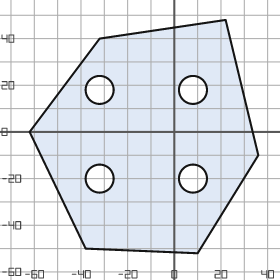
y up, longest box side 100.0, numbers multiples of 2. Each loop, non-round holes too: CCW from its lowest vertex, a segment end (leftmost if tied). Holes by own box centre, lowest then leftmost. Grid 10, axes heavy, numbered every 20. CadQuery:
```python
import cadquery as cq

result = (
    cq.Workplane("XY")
    .moveTo(10.0, -52.0)
    .lineTo(36.0, -10.0)
    .lineTo(22.0, 48.0)
    .lineTo(-32.0, 40.0)
    .lineTo(-62.0, 0.0)
    .lineTo(-38.0, -50.0)
    .close()
    .moveTo(-32.0, -20.0)
    .circle(6.0)
    .moveTo(8.0, -20.0)
    .circle(6.0)
    .moveTo(-32.0, 18.0)
    .circle(6.0)
    .moveTo(8.0, 18.0)
    .circle(6.0)
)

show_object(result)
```